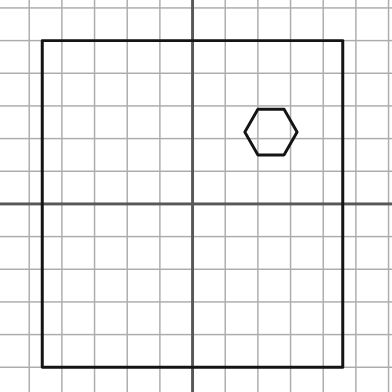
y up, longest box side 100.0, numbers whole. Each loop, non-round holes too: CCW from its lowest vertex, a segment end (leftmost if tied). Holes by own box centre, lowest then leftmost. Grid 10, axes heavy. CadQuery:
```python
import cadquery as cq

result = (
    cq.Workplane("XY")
    .moveTo(-46.0, -50.0)
    .lineTo(46.0, -50.0)
    .lineTo(46.0, 50.0)
    .lineTo(-46.0, 50.0)
    .close()
    .moveTo(20.0, 15.0)
    .lineTo(28.0, 15.0)
    .lineTo(32.0, 22.0)
    .lineTo(28.0, 29.0)
    .lineTo(20.0, 29.0)
    .lineTo(16.0, 22.0)
    .close()
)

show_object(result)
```